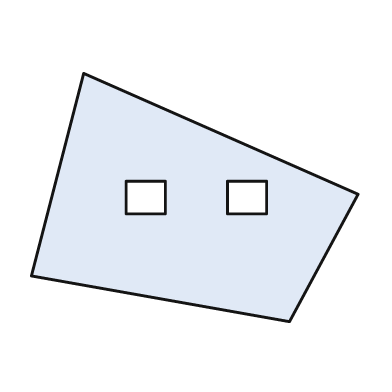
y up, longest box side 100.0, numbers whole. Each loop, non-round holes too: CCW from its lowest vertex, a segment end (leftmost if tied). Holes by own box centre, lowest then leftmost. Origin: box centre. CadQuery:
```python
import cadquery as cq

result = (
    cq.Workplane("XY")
    .moveTo(29.0, -38.0)
    .lineTo(50.0, 1.0)
    .lineTo(-34.0, 38.0)
    .lineTo(-50.0, -24.0)
    .close()
    .moveTo(-21.0, -5.0)
    .lineTo(-9.0, -5.0)
    .lineTo(-9.0, 5.0)
    .lineTo(-21.0, 5.0)
    .close()
    .moveTo(10.0, -5.0)
    .lineTo(22.0, -5.0)
    .lineTo(22.0, 5.0)
    .lineTo(10.0, 5.0)
    .close()
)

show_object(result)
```